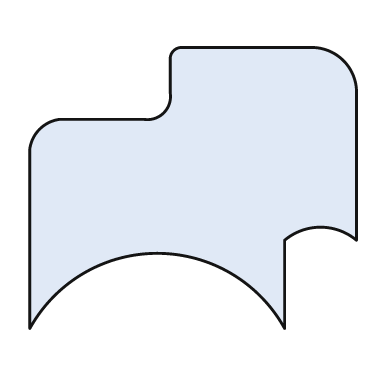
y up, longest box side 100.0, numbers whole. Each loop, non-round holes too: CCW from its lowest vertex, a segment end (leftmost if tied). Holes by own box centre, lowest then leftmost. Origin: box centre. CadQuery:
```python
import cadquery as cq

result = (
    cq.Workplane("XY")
    .moveTo(-50.0, -43.0)
    .threePointArc((-11.0, -20.0), (28.0, -43.0))
    .lineTo(28.0, -16.0)
    .threePointArc((39.0, -12.0), (50.0, -16.0))
    .lineTo(50.0, 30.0)
    .threePointArc((46.0, 39.0), (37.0, 43.0))
    .lineTo(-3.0, 43.0)
    .threePointArc((-6.0, 42.0), (-7.0, 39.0))
    .lineTo(-7.0, 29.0)
    .threePointArc((-9.0, 23.0), (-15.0, 21.0))
    .lineTo(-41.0, 21.0)
    .threePointArc((-47.0, 18.0), (-50.0, 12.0))
    .close()
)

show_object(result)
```